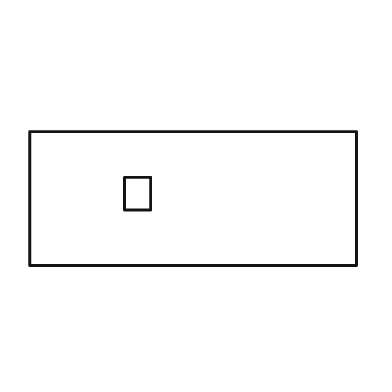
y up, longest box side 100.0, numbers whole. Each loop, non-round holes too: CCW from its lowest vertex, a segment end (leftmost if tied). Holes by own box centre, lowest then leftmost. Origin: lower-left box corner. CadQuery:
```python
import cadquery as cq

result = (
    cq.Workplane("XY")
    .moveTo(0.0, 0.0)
    .lineTo(100.0, 0.0)
    .lineTo(100.0, 41.0)
    .lineTo(0.0, 41.0)
    .close()
    .moveTo(29.0, 17.0)
    .lineTo(37.0, 17.0)
    .lineTo(37.0, 27.0)
    .lineTo(29.0, 27.0)
    .close()
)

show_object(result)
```